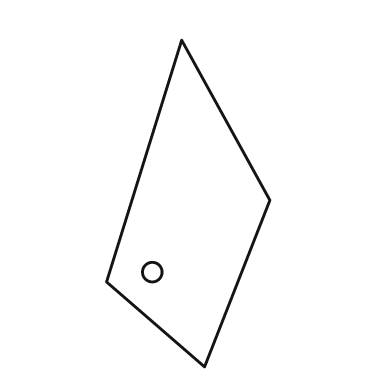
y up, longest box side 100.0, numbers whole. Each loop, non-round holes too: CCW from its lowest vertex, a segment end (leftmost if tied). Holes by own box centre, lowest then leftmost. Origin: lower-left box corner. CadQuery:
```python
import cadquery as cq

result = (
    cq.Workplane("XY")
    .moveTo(30.0, 0.0)
    .lineTo(50.0, 51.0)
    .lineTo(23.0, 100.0)
    .lineTo(0.0, 26.0)
    .close()
    .moveTo(14.0, 29.0)
    .circle(3.0)
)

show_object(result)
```